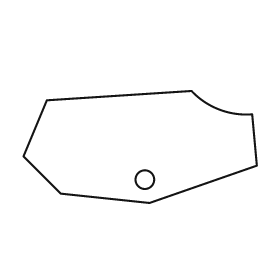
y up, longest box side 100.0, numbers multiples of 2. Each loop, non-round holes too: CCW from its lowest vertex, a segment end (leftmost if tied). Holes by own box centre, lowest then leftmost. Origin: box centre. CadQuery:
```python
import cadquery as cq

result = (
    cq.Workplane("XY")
    .moveTo(4.0, -24.0)
    .lineTo(50.0, -8.0)
    .lineTo(48.0, 14.0)
    .threePointArc((34.0, 16.0), (22.0, 24.0))
    .lineTo(-40.0, 20.0)
    .lineTo(-50.0, -4.0)
    .lineTo(-34.0, -20.0)
    .close()
    .moveTo(2.0, -14.0)
    .circle(4.0)
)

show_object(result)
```